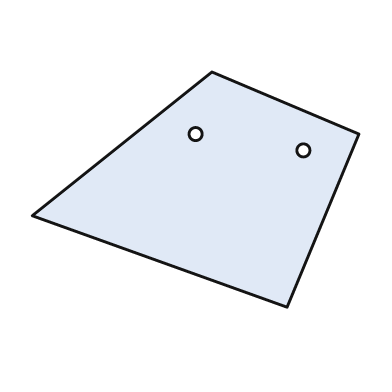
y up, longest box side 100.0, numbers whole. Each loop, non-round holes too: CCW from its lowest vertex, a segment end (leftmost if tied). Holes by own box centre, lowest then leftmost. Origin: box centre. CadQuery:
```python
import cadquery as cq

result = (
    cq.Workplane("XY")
    .moveTo(28.0, -36.0)
    .lineTo(50.0, 17.0)
    .lineTo(5.0, 36.0)
    .lineTo(-50.0, -8.0)
    .close()
    .moveTo(33.0, 12.0)
    .circle(2.0)
    .moveTo(0.0, 17.0)
    .circle(2.0)
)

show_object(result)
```